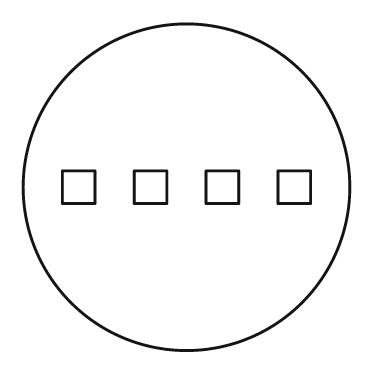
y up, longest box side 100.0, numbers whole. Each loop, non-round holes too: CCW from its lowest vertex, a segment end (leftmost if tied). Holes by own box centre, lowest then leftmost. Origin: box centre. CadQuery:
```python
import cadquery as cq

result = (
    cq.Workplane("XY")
    .moveTo(0.0, 0.0)
    .circle(50.0)
    .moveTo(-38.0, -5.0)
    .lineTo(-28.0, -5.0)
    .lineTo(-28.0, 5.0)
    .lineTo(-38.0, 5.0)
    .close()
    .moveTo(-16.0, -5.0)
    .lineTo(-6.0, -5.0)
    .lineTo(-6.0, 5.0)
    .lineTo(-16.0, 5.0)
    .close()
    .moveTo(6.0, -5.0)
    .lineTo(16.0, -5.0)
    .lineTo(16.0, 5.0)
    .lineTo(6.0, 5.0)
    .close()
    .moveTo(28.0, -5.0)
    .lineTo(38.0, -5.0)
    .lineTo(38.0, 5.0)
    .lineTo(28.0, 5.0)
    .close()
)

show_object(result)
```